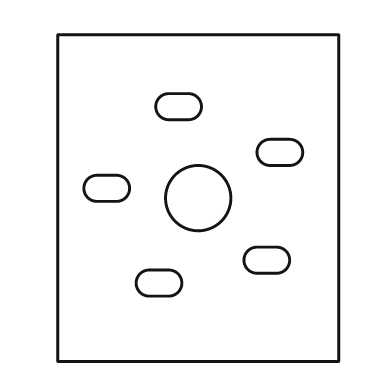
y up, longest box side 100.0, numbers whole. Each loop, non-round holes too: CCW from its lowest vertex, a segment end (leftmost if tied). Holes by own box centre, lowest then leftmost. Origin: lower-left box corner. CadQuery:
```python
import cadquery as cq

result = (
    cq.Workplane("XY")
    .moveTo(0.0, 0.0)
    .lineTo(86.0, 0.0)
    .lineTo(86.0, 100.0)
    .lineTo(0.0, 100.0)
    .close()
    .moveTo(28.0, 20.0)
    .lineTo(34.0, 20.0)
    .threePointArc((38.0, 24.0), (34.0, 28.0))
    .lineTo(28.0, 28.0)
    .threePointArc((24.0, 24.0), (28.0, 20.0))
    .close()
    .moveTo(61.0, 27.0)
    .lineTo(67.0, 27.0)
    .threePointArc((71.0, 31.0), (67.0, 35.0))
    .lineTo(61.0, 35.0)
    .threePointArc((57.0, 31.0), (61.0, 27.0))
    .close()
    .moveTo(43.0, 50.0)
    .circle(10.0)
    .moveTo(12.0, 49.0)
    .lineTo(18.0, 49.0)
    .threePointArc((22.0, 53.0), (18.0, 57.0))
    .lineTo(12.0, 57.0)
    .threePointArc((8.0, 53.0), (12.0, 49.0))
    .close()
    .moveTo(65.0, 60.0)
    .lineTo(71.0, 60.0)
    .threePointArc((75.0, 64.0), (71.0, 68.0))
    .lineTo(65.0, 68.0)
    .threePointArc((61.0, 64.0), (65.0, 60.0))
    .close()
    .moveTo(34.0, 74.0)
    .lineTo(40.0, 74.0)
    .threePointArc((44.0, 78.0), (40.0, 82.0))
    .lineTo(34.0, 82.0)
    .threePointArc((30.0, 78.0), (34.0, 74.0))
    .close()
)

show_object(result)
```